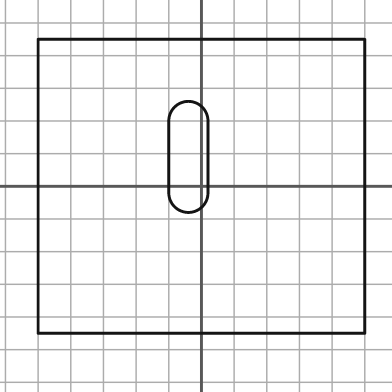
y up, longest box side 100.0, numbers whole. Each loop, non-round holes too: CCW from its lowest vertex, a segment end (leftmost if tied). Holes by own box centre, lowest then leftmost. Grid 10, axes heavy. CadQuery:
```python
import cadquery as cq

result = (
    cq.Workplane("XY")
    .moveTo(-50.0, -45.0)
    .lineTo(50.0, -45.0)
    .lineTo(50.0, 45.0)
    .lineTo(-50.0, 45.0)
    .close()
    .moveTo(-10.0, -2.0)
    .threePointArc((-4.0, -8.0), (2.0, -2.0))
    .lineTo(2.0, 20.0)
    .threePointArc((-4.0, 26.0), (-10.0, 20.0))
    .close()
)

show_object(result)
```